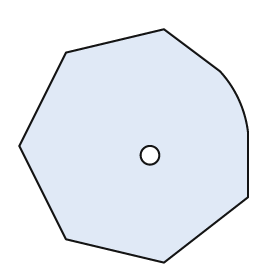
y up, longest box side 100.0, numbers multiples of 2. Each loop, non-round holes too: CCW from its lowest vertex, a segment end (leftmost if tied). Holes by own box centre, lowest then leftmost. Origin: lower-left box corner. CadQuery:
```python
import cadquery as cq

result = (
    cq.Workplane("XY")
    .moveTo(62.0, 0.0)
    .lineTo(98.0, 28.0)
    .lineTo(98.0, 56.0)
    .threePointArc((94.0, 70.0), (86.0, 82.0))
    .lineTo(62.0, 100.0)
    .lineTo(20.0, 90.0)
    .lineTo(0.0, 50.0)
    .lineTo(20.0, 10.0)
    .close()
    .moveTo(56.0, 46.0)
    .circle(4.0)
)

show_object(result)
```